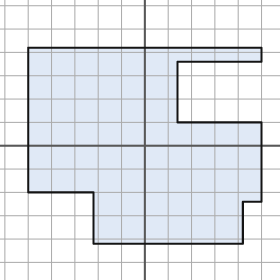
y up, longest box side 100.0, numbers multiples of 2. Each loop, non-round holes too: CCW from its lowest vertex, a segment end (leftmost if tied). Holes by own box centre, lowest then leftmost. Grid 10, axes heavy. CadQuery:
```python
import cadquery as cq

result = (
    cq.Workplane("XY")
    .moveTo(-22.0, -42.0)
    .lineTo(42.0, -42.0)
    .lineTo(42.0, -24.0)
    .lineTo(50.0, -24.0)
    .lineTo(50.0, 10.0)
    .lineTo(14.0, 10.0)
    .lineTo(14.0, 36.0)
    .lineTo(50.0, 36.0)
    .lineTo(50.0, 42.0)
    .lineTo(-50.0, 42.0)
    .lineTo(-50.0, -20.0)
    .lineTo(-22.0, -20.0)
    .close()
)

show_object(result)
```